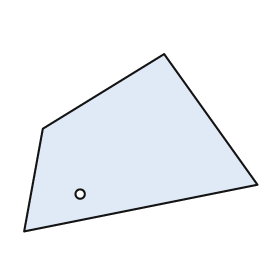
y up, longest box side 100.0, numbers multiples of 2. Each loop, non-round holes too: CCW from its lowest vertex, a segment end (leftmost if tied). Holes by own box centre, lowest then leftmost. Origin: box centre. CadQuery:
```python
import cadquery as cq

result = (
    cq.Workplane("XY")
    .moveTo(-50.0, -38.0)
    .lineTo(50.0, -18.0)
    .lineTo(10.0, 38.0)
    .lineTo(-42.0, 6.0)
    .close()
    .moveTo(-26.0, -22.0)
    .circle(2.0)
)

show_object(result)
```